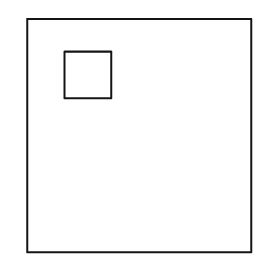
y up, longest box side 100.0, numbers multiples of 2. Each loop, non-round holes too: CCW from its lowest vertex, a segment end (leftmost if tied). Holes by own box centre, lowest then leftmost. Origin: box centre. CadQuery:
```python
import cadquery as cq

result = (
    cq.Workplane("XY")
    .moveTo(-48.0, -50.0)
    .lineTo(48.0, -50.0)
    .lineTo(48.0, 50.0)
    .lineTo(-48.0, 50.0)
    .close()
    .moveTo(-32.0, 16.0)
    .lineTo(-12.0, 16.0)
    .lineTo(-12.0, 36.0)
    .lineTo(-32.0, 36.0)
    .close()
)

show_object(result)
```